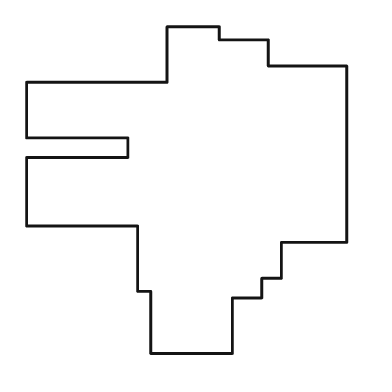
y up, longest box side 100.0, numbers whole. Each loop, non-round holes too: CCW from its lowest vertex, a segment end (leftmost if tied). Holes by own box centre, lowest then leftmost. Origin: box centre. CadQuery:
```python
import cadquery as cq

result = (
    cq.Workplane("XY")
    .moveTo(-11.0, -50.0)
    .lineTo(14.0, -50.0)
    .lineTo(14.0, -33.0)
    .lineTo(23.0, -33.0)
    .lineTo(23.0, -27.0)
    .lineTo(29.0, -27.0)
    .lineTo(29.0, -16.0)
    .lineTo(49.0, -16.0)
    .lineTo(49.0, 38.0)
    .lineTo(25.0, 38.0)
    .lineTo(25.0, 46.0)
    .lineTo(10.0, 46.0)
    .lineTo(10.0, 50.0)
    .lineTo(-6.0, 50.0)
    .lineTo(-6.0, 33.0)
    .lineTo(-49.0, 33.0)
    .lineTo(-49.0, 16.0)
    .lineTo(-18.0, 16.0)
    .lineTo(-18.0, 10.0)
    .lineTo(-49.0, 10.0)
    .lineTo(-49.0, -11.0)
    .lineTo(-15.0, -11.0)
    .lineTo(-15.0, -31.0)
    .lineTo(-11.0, -31.0)
    .close()
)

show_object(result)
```